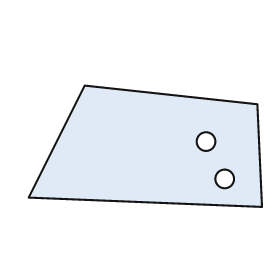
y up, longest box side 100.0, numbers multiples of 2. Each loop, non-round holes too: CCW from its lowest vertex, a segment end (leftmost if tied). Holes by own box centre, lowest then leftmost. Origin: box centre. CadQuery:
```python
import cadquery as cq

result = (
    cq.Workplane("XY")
    .moveTo(50.0, -26.0)
    .lineTo(48.0, 18.0)
    .lineTo(-26.0, 26.0)
    .lineTo(-50.0, -22.0)
    .close()
    .moveTo(34.0, -14.0)
    .circle(4.0)
    .moveTo(26.0, 2.0)
    .circle(4.0)
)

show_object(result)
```